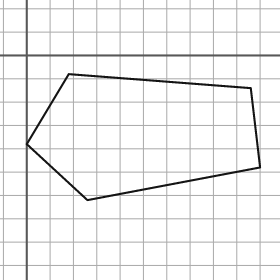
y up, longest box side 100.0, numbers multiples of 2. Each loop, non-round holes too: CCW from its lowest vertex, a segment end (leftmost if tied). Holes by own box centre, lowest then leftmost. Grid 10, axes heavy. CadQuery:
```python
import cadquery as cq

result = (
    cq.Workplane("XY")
    .moveTo(26.0, -62.0)
    .lineTo(100.0, -48.0)
    .lineTo(96.0, -14.0)
    .lineTo(18.0, -8.0)
    .lineTo(0.0, -38.0)
    .close()
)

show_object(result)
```